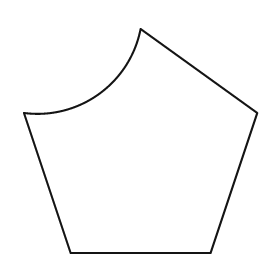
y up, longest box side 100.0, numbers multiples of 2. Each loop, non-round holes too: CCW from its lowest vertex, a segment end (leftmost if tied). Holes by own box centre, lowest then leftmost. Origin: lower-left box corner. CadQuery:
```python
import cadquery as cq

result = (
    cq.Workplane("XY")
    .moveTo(20.0, 0.0)
    .lineTo(80.0, 0.0)
    .lineTo(100.0, 60.0)
    .lineTo(50.0, 96.0)
    .threePointArc((32.0, 68.0), (0.0, 60.0))
    .close()
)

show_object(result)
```